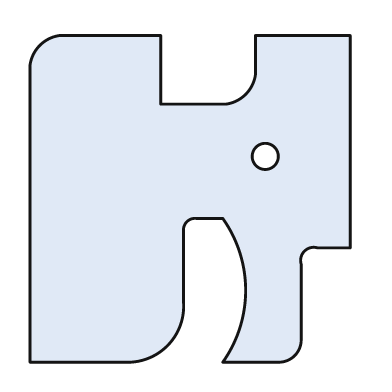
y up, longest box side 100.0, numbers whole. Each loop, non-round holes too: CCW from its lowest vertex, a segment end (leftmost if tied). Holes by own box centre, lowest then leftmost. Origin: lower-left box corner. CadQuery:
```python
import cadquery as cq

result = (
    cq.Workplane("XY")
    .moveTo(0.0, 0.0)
    .lineTo(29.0, 0.0)
    .threePointArc((42.0, 5.0), (47.0, 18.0))
    .lineTo(47.0, 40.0)
    .threePointArc((48.0, 43.0), (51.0, 44.0))
    .lineTo(59.0, 44.0)
    .threePointArc((66.0, 22.0), (59.0, 0.0))
    .lineTo(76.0, 0.0)
    .threePointArc((81.0, 2.0), (83.0, 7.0))
    .lineTo(83.0, 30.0)
    .threePointArc((84.0, 34.0), (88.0, 35.0))
    .lineTo(98.0, 35.0)
    .lineTo(98.0, 100.0)
    .lineTo(69.0, 100.0)
    .lineTo(69.0, 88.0)
    .threePointArc((66.0, 82.0), (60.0, 79.0))
    .lineTo(40.0, 79.0)
    .lineTo(40.0, 100.0)
    .lineTo(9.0, 100.0)
    .threePointArc((3.0, 97.0), (0.0, 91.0))
    .close()
    .moveTo(72.0, 63.0)
    .circle(4.0)
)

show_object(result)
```